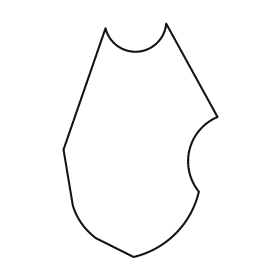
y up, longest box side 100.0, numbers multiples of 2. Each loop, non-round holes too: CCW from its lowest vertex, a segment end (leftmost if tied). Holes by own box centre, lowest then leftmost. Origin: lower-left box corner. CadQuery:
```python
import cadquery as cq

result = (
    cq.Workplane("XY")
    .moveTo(30.0, 0.0)
    .threePointArc((48.0, 10.0), (58.0, 28.0))
    .threePointArc((54.0, 46.0), (66.0, 60.0))
    .lineTo(44.0, 100.0)
    .threePointArc((32.0, 88.0), (18.0, 98.0))
    .lineTo(0.0, 46.0)
    .lineTo(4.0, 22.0)
    .threePointArc((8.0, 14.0), (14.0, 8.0))
    .close()
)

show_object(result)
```